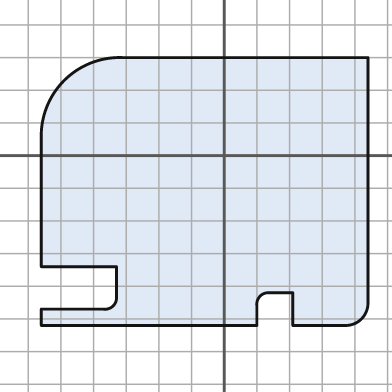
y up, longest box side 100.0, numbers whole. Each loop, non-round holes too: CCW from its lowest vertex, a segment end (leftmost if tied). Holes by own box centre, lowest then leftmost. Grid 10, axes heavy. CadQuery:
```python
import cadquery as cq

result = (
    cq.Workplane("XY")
    .moveTo(-56.0, -52.0)
    .lineTo(10.0, -52.0)
    .lineTo(10.0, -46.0)
    .threePointArc((11.0, -43.0), (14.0, -42.0))
    .lineTo(21.0, -42.0)
    .lineTo(21.0, -52.0)
    .lineTo(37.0, -52.0)
    .threePointArc((42.0, -50.0), (44.0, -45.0))
    .lineTo(44.0, 30.0)
    .lineTo(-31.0, 30.0)
    .threePointArc((-49.0, 23.0), (-56.0, 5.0))
    .lineTo(-56.0, -34.0)
    .lineTo(-33.0, -34.0)
    .lineTo(-33.0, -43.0)
    .threePointArc((-34.0, -46.0), (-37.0, -47.0))
    .lineTo(-56.0, -47.0)
    .close()
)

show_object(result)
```